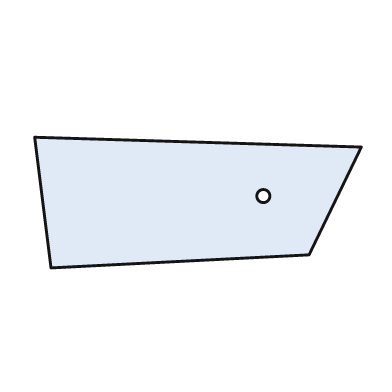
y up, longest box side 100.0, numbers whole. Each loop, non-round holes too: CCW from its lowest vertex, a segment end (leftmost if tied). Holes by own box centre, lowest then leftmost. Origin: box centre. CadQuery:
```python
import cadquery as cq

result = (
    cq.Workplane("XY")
    .moveTo(-45.0, -20.0)
    .lineTo(34.0, -16.0)
    .lineTo(50.0, 17.0)
    .lineTo(-50.0, 20.0)
    .close()
    .moveTo(20.0, 2.0)
    .circle(2.0)
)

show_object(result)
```